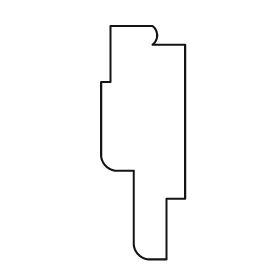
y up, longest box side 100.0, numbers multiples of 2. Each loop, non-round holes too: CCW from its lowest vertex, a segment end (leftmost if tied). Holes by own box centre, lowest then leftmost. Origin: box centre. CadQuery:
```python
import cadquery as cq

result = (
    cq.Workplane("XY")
    .moveTo(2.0, -50.0)
    .lineTo(10.0, -50.0)
    .lineTo(10.0, -24.0)
    .lineTo(18.0, -24.0)
    .lineTo(18.0, 42.0)
    .lineTo(4.0, 42.0)
    .threePointArc((6.0, 46.0), (4.0, 50.0))
    .lineTo(-14.0, 50.0)
    .lineTo(-14.0, 26.0)
    .lineTo(-18.0, 26.0)
    .lineTo(-18.0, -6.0)
    .threePointArc((-16.0, -10.0), (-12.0, -12.0))
    .lineTo(-4.0, -12.0)
    .lineTo(-4.0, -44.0)
    .threePointArc((-2.0, -48.0), (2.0, -50.0))
    .close()
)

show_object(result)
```